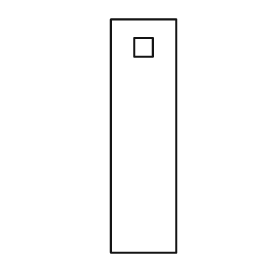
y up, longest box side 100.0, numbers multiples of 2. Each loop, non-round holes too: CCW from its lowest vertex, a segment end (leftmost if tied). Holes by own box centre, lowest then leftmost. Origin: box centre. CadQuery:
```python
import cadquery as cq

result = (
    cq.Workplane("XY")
    .moveTo(-14.0, -50.0)
    .lineTo(14.0, -50.0)
    .lineTo(14.0, 50.0)
    .lineTo(-14.0, 50.0)
    .close()
    .moveTo(-4.0, 34.0)
    .lineTo(4.0, 34.0)
    .lineTo(4.0, 42.0)
    .lineTo(-4.0, 42.0)
    .close()
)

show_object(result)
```